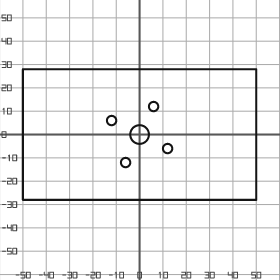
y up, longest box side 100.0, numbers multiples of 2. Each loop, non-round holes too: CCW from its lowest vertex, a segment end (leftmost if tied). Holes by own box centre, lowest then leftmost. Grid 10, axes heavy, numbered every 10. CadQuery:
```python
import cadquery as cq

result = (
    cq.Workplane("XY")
    .moveTo(-50.0, -28.0)
    .lineTo(50.0, -28.0)
    .lineTo(50.0, 28.0)
    .lineTo(-50.0, 28.0)
    .close()
    .moveTo(-6.0, -12.0)
    .circle(2.0)
    .moveTo(12.0, -6.0)
    .circle(2.0)
    .moveTo(0.0, 0.0)
    .circle(4.0)
    .moveTo(-12.0, 6.0)
    .circle(2.0)
    .moveTo(6.0, 12.0)
    .circle(2.0)
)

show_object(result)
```